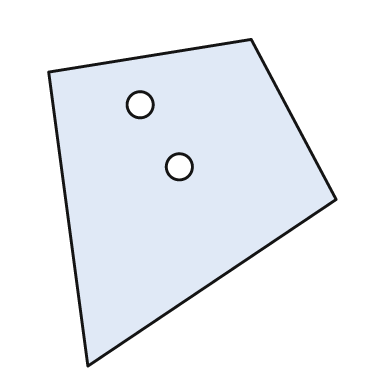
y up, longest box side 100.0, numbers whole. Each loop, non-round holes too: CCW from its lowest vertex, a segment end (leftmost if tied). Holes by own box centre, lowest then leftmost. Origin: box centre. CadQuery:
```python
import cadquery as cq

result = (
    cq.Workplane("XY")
    .moveTo(-32.0, -50.0)
    .lineTo(44.0, 1.0)
    .lineTo(18.0, 50.0)
    .lineTo(-44.0, 40.0)
    .close()
    .moveTo(-4.0, 11.0)
    .circle(4.0)
    .moveTo(-16.0, 30.0)
    .circle(4.0)
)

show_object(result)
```